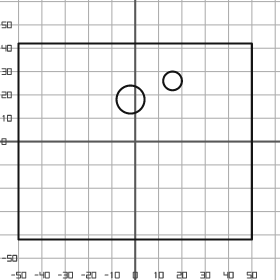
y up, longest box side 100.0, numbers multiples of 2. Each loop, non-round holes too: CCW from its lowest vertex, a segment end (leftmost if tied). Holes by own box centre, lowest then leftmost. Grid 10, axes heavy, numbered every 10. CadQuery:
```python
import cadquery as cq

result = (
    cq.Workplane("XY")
    .moveTo(-50.0, -42.0)
    .lineTo(50.0, -42.0)
    .lineTo(50.0, 42.0)
    .lineTo(-50.0, 42.0)
    .close()
    .moveTo(-2.0, 18.0)
    .circle(6.0)
    .moveTo(16.0, 26.0)
    .circle(4.0)
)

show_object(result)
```